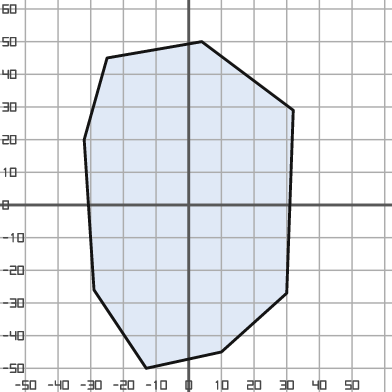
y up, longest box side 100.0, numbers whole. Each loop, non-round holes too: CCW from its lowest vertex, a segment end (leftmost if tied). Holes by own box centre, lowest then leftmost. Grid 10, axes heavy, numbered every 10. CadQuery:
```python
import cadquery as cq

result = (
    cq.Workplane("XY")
    .moveTo(-13.0, -50.0)
    .lineTo(10.0, -45.0)
    .lineTo(30.0, -27.0)
    .lineTo(32.0, 29.0)
    .lineTo(4.0, 50.0)
    .lineTo(-25.0, 45.0)
    .lineTo(-32.0, 20.0)
    .lineTo(-29.0, -26.0)
    .close()
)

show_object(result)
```